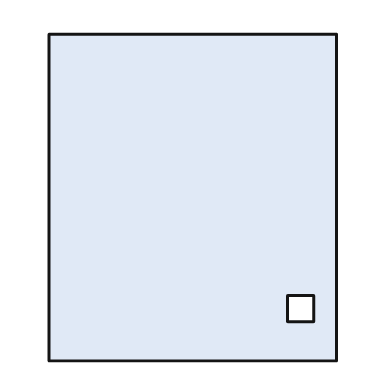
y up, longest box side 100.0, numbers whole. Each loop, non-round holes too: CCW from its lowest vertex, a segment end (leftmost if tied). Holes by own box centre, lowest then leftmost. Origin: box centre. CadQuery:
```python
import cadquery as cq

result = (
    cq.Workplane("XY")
    .moveTo(-44.0, -50.0)
    .lineTo(44.0, -50.0)
    .lineTo(44.0, 50.0)
    .lineTo(-44.0, 50.0)
    .close()
    .moveTo(29.0, -38.0)
    .lineTo(37.0, -38.0)
    .lineTo(37.0, -30.0)
    .lineTo(29.0, -30.0)
    .close()
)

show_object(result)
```